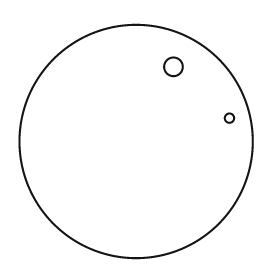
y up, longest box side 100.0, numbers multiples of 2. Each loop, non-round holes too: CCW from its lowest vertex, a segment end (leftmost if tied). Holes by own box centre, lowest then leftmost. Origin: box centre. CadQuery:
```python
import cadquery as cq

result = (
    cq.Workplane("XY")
    .moveTo(0.0, 0.0)
    .circle(50.0)
    .moveTo(40.0, 10.0)
    .circle(2.0)
    .moveTo(16.0, 32.0)
    .circle(4.0)
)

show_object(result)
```